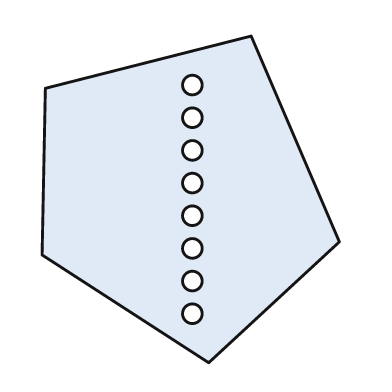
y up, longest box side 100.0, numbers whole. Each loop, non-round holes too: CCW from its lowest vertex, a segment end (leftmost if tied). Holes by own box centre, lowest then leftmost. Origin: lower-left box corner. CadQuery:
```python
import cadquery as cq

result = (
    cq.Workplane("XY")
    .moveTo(51.0, 0.0)
    .lineTo(91.0, 37.0)
    .lineTo(64.0, 100.0)
    .lineTo(1.0, 84.0)
    .lineTo(0.0, 33.0)
    .close()
    .moveTo(46.0, 15.0)
    .circle(3.0)
    .moveTo(46.0, 25.0)
    .circle(3.0)
    .moveTo(46.0, 35.0)
    .circle(3.0)
    .moveTo(46.0, 45.0)
    .circle(3.0)
    .moveTo(46.0, 55.0)
    .circle(3.0)
    .moveTo(46.0, 65.0)
    .circle(3.0)
    .moveTo(46.0, 75.0)
    .circle(3.0)
    .moveTo(46.0, 85.0)
    .circle(3.0)
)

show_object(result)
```